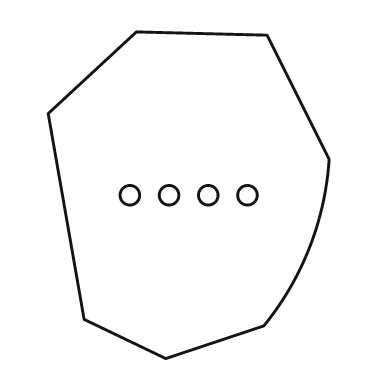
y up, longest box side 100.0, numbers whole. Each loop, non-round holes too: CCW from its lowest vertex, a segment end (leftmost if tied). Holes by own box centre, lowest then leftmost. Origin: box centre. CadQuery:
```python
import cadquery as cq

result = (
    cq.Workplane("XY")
    .moveTo(-7.0, -50.0)
    .lineTo(23.0, -40.0)
    .threePointArc((37.0, -16.0), (43.0, 11.0))
    .lineTo(24.0, 49.0)
    .lineTo(-16.0, 50.0)
    .lineTo(-43.0, 25.0)
    .lineTo(-32.0, -38.0)
    .close()
    .moveTo(-18.0, 0.0)
    .circle(3.0)
    .moveTo(-6.0, 0.0)
    .circle(3.0)
    .moveTo(6.0, 0.0)
    .circle(3.0)
    .moveTo(18.0, 0.0)
    .circle(3.0)
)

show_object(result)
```